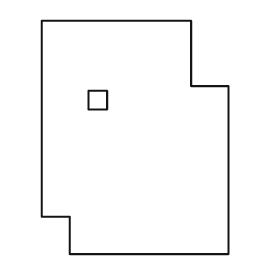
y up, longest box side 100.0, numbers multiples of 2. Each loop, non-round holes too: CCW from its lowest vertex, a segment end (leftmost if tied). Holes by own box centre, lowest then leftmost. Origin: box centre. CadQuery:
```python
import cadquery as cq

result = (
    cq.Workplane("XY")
    .moveTo(-28.0, -50.0)
    .lineTo(40.0, -50.0)
    .lineTo(40.0, 22.0)
    .lineTo(24.0, 22.0)
    .lineTo(24.0, 50.0)
    .lineTo(-40.0, 50.0)
    .lineTo(-40.0, -34.0)
    .lineTo(-28.0, -34.0)
    .close()
    .moveTo(-20.0, 12.0)
    .lineTo(-12.0, 12.0)
    .lineTo(-12.0, 20.0)
    .lineTo(-20.0, 20.0)
    .close()
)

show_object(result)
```